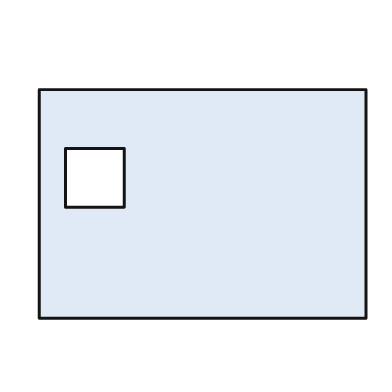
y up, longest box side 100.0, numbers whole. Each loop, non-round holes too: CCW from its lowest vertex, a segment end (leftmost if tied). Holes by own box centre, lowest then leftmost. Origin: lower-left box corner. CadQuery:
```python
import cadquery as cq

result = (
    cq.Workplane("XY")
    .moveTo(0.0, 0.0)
    .lineTo(100.0, 0.0)
    .lineTo(100.0, 70.0)
    .lineTo(0.0, 70.0)
    .close()
    .moveTo(8.0, 34.0)
    .lineTo(26.0, 34.0)
    .lineTo(26.0, 52.0)
    .lineTo(8.0, 52.0)
    .close()
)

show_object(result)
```